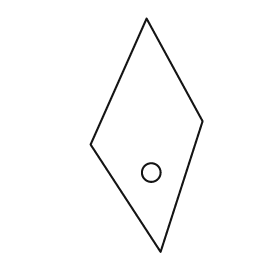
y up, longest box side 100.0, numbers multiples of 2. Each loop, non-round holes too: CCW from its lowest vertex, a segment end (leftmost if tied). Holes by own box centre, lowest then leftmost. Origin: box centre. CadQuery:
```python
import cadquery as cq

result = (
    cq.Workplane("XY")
    .moveTo(6.0, -50.0)
    .lineTo(24.0, 6.0)
    .lineTo(0.0, 50.0)
    .lineTo(-24.0, -4.0)
    .close()
    .moveTo(2.0, -16.0)
    .circle(4.0)
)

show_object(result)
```